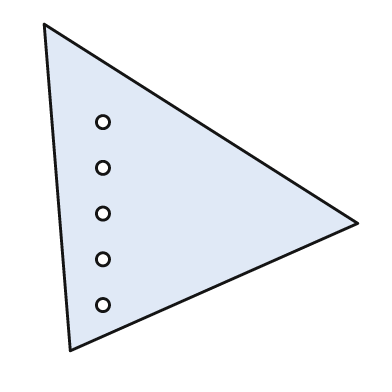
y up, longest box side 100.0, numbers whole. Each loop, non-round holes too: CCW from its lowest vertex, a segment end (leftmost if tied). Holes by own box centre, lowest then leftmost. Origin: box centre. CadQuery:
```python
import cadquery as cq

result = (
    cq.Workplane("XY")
    .moveTo(-40.0, -50.0)
    .lineTo(48.0, -11.0)
    .lineTo(-48.0, 50.0)
    .close()
    .moveTo(-30.0, -36.0)
    .circle(2.0)
    .moveTo(-30.0, -22.0)
    .circle(2.0)
    .moveTo(-30.0, -8.0)
    .circle(2.0)
    .moveTo(-30.0, 6.0)
    .circle(2.0)
    .moveTo(-30.0, 20.0)
    .circle(2.0)
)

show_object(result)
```